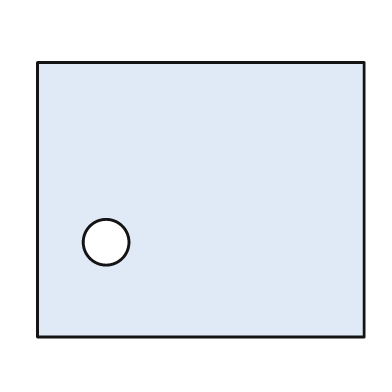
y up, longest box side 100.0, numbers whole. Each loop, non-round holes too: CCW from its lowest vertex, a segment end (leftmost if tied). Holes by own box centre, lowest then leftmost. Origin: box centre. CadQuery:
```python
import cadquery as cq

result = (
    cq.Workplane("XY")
    .moveTo(-50.0, -42.0)
    .lineTo(50.0, -42.0)
    .lineTo(50.0, 42.0)
    .lineTo(-50.0, 42.0)
    .close()
    .moveTo(-29.0, -13.0)
    .circle(7.0)
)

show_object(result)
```